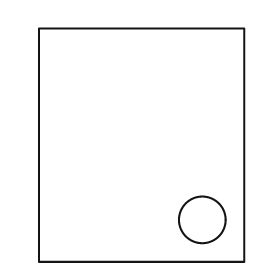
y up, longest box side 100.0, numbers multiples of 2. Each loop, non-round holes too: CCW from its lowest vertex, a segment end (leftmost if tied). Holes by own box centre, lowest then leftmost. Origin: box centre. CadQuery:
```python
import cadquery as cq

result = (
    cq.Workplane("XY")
    .moveTo(-44.0, -50.0)
    .lineTo(44.0, -50.0)
    .lineTo(44.0, 50.0)
    .lineTo(-44.0, 50.0)
    .close()
    .moveTo(26.0, -32.0)
    .circle(10.0)
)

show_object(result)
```